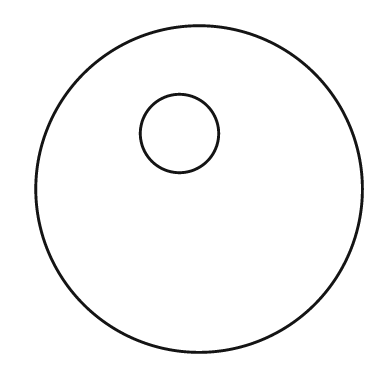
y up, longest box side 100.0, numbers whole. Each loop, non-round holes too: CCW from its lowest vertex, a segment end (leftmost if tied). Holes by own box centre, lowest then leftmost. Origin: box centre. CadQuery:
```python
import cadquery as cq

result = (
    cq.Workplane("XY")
    .moveTo(0.0, 0.0)
    .circle(50.0)
    .moveTo(-6.0, 17.0)
    .circle(12.0)
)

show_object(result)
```